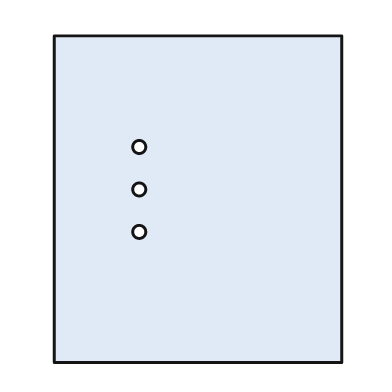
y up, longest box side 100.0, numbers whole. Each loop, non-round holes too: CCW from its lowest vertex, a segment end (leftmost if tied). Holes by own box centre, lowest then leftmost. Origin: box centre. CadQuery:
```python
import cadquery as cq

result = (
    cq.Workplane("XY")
    .moveTo(-44.0, -50.0)
    .lineTo(44.0, -50.0)
    .lineTo(44.0, 50.0)
    .lineTo(-44.0, 50.0)
    .close()
    .moveTo(-18.0, -10.0)
    .circle(2.0)
    .moveTo(-18.0, 3.0)
    .circle(2.0)
    .moveTo(-18.0, 16.0)
    .circle(2.0)
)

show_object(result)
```